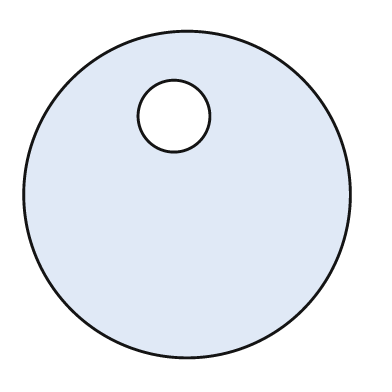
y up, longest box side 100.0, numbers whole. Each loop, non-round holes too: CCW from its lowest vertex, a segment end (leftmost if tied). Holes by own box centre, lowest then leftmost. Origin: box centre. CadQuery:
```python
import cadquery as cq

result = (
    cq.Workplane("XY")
    .moveTo(0.0, 0.0)
    .circle(50.0)
    .moveTo(-4.0, 24.0)
    .circle(11.0)
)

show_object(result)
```